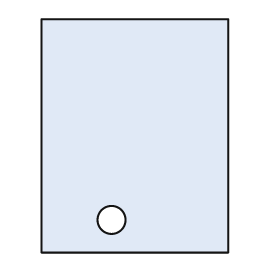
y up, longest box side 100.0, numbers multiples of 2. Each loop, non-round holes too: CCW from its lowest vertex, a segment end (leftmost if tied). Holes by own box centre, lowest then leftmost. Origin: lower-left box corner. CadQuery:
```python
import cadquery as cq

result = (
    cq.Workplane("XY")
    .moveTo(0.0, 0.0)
    .lineTo(80.0, 0.0)
    .lineTo(80.0, 100.0)
    .lineTo(0.0, 100.0)
    .close()
    .moveTo(30.0, 14.0)
    .circle(6.0)
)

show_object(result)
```